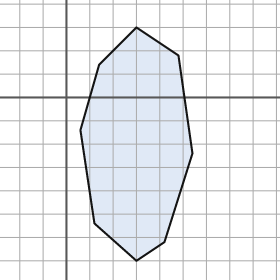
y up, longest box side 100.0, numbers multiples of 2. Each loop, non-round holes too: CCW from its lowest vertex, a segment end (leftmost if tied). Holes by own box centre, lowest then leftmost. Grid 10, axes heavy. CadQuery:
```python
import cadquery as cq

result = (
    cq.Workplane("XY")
    .moveTo(30.0, -70.0)
    .lineTo(42.0, -62.0)
    .lineTo(54.0, -24.0)
    .lineTo(48.0, 18.0)
    .lineTo(30.0, 30.0)
    .lineTo(14.0, 14.0)
    .lineTo(6.0, -14.0)
    .lineTo(12.0, -54.0)
    .close()
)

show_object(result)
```